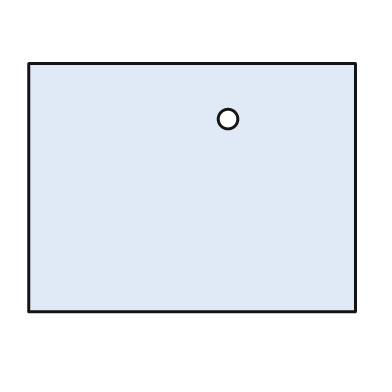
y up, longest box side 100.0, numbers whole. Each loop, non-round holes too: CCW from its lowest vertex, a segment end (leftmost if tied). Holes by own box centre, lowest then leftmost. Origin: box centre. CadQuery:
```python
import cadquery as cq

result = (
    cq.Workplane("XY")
    .moveTo(-50.0, -38.0)
    .lineTo(50.0, -38.0)
    .lineTo(50.0, 38.0)
    .lineTo(-50.0, 38.0)
    .close()
    .moveTo(11.0, 21.0)
    .circle(3.0)
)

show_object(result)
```